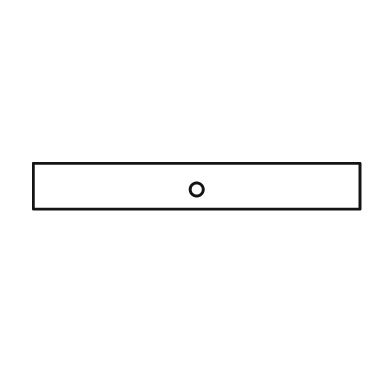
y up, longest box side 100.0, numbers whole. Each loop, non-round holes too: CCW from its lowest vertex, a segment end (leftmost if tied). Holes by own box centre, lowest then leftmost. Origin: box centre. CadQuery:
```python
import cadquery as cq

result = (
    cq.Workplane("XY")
    .moveTo(-50.0, -7.0)
    .lineTo(50.0, -7.0)
    .lineTo(50.0, 7.0)
    .lineTo(-50.0, 7.0)
    .close()
    .moveTo(0.0, -1.0)
    .circle(2.0)
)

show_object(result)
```